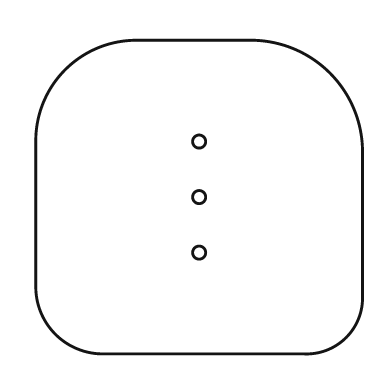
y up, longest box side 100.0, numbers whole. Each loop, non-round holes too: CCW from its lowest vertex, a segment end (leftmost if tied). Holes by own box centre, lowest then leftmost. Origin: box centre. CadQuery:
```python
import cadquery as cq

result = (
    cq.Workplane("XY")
    .moveTo(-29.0, -48.0)
    .lineTo(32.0, -48.0)
    .threePointArc((45.0, -43.0), (50.0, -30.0))
    .lineTo(50.0, 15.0)
    .threePointArc((40.0, 38.0), (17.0, 48.0))
    .lineTo(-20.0, 48.0)
    .threePointArc((-41.0, 39.0), (-50.0, 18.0))
    .lineTo(-50.0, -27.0)
    .threePointArc((-44.0, -42.0), (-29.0, -48.0))
    .close()
    .moveTo(0.0, -17.0)
    .circle(2.0)
    .moveTo(0.0, 0.0)
    .circle(2.0)
    .moveTo(0.0, 17.0)
    .circle(2.0)
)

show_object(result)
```